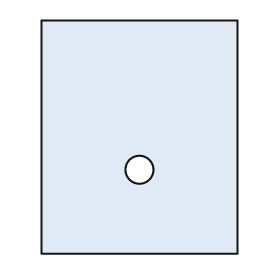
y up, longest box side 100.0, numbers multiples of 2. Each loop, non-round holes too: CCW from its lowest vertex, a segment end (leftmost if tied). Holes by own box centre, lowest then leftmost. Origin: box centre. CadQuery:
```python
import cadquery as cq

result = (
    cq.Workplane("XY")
    .moveTo(-42.0, -50.0)
    .lineTo(42.0, -50.0)
    .lineTo(42.0, 50.0)
    .lineTo(-42.0, 50.0)
    .close()
    .moveTo(0.0, -14.0)
    .circle(6.0)
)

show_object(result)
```